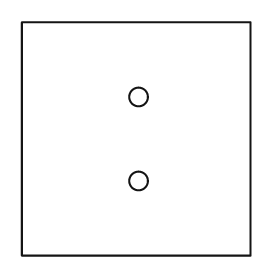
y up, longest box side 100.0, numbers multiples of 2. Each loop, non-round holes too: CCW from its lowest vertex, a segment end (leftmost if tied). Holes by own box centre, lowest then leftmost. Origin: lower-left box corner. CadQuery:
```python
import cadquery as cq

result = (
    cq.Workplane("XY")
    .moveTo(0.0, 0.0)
    .lineTo(98.0, 0.0)
    .lineTo(98.0, 100.0)
    .lineTo(0.0, 100.0)
    .close()
    .moveTo(50.0, 32.0)
    .circle(4.0)
    .moveTo(50.0, 68.0)
    .circle(4.0)
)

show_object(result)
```